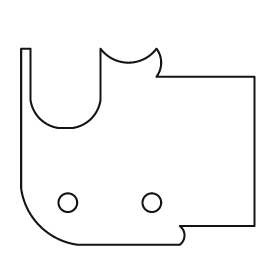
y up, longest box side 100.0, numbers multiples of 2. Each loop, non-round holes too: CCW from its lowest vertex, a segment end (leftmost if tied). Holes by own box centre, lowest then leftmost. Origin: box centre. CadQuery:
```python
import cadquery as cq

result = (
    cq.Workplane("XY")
    .moveTo(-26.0, -42.0)
    .lineTo(18.0, -42.0)
    .threePointArc((20.0, -38.0), (18.0, -34.0))
    .lineTo(50.0, -34.0)
    .lineTo(50.0, 30.0)
    .lineTo(8.0, 30.0)
    .threePointArc((10.0, 36.0), (8.0, 42.0))
    .threePointArc((-4.0, 36.0), (-16.0, 42.0))
    .lineTo(-16.0, 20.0)
    .threePointArc((-20.0, 12.0), (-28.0, 8.0))
    .lineTo(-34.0, 8.0)
    .threePointArc((-42.0, 12.0), (-46.0, 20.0))
    .lineTo(-46.0, 42.0)
    .lineTo(-50.0, 42.0)
    .lineTo(-50.0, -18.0)
    .threePointArc((-42.0, -34.0), (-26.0, -42.0))
    .close()
    .moveTo(-30.0, -24.0)
    .circle(4.0)
    .moveTo(6.0, -24.0)
    .circle(4.0)
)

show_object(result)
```